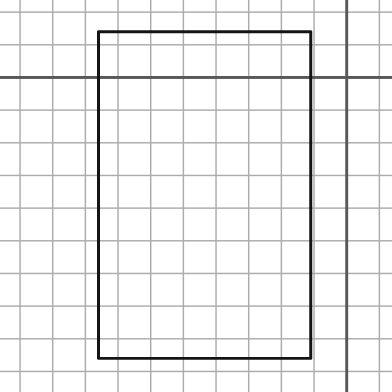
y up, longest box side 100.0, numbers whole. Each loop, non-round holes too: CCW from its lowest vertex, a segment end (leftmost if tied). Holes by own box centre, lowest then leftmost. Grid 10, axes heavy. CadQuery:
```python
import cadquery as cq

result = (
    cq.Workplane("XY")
    .moveTo(-76.0, -86.0)
    .lineTo(-11.0, -86.0)
    .lineTo(-11.0, 14.0)
    .lineTo(-76.0, 14.0)
    .close()
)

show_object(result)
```